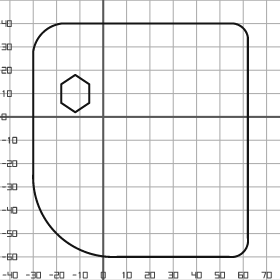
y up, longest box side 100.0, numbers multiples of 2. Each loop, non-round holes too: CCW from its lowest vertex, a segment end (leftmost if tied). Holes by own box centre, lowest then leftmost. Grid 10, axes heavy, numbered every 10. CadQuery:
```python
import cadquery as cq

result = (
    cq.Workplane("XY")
    .moveTo(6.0, -60.0)
    .lineTo(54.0, -60.0)
    .threePointArc((60.0, -58.0), (62.0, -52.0))
    .lineTo(62.0, 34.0)
    .threePointArc((60.0, 38.0), (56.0, 40.0))
    .lineTo(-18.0, 40.0)
    .threePointArc((-26.0, 36.0), (-30.0, 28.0))
    .lineTo(-30.0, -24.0)
    .threePointArc((-20.0, -50.0), (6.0, -60.0))
    .close()
    .moveTo(-12.0, 2.0)
    .lineTo(-6.0, 6.0)
    .lineTo(-6.0, 14.0)
    .lineTo(-12.0, 18.0)
    .lineTo(-18.0, 14.0)
    .lineTo(-18.0, 6.0)
    .close()
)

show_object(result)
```